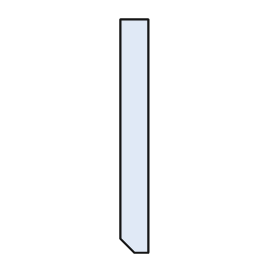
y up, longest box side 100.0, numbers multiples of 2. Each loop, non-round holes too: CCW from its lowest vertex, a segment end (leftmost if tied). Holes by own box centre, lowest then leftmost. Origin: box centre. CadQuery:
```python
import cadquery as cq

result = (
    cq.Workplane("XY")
    .moveTo(0.0, -50.0)
    .lineTo(6.0, -50.0)
    .lineTo(6.0, 50.0)
    .lineTo(-6.0, 50.0)
    .lineTo(-6.0, -44.0)
    .close()
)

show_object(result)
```